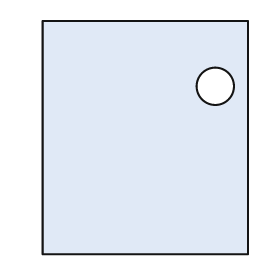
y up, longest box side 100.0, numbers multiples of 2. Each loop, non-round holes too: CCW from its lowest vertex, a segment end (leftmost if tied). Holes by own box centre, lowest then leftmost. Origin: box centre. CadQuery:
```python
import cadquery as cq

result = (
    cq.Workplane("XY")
    .moveTo(-44.0, -50.0)
    .lineTo(44.0, -50.0)
    .lineTo(44.0, 50.0)
    .lineTo(-44.0, 50.0)
    .close()
    .moveTo(30.0, 22.0)
    .circle(8.0)
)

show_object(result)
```